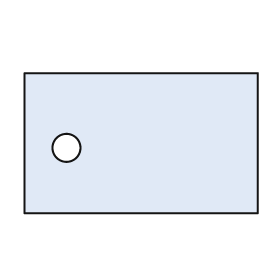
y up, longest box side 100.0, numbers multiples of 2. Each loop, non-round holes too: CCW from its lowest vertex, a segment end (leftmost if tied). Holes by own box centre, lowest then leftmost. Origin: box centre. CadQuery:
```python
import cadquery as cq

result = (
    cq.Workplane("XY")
    .moveTo(-50.0, -30.0)
    .lineTo(50.0, -30.0)
    .lineTo(50.0, 30.0)
    .lineTo(-50.0, 30.0)
    .close()
    .moveTo(-32.0, -2.0)
    .circle(6.0)
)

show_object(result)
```